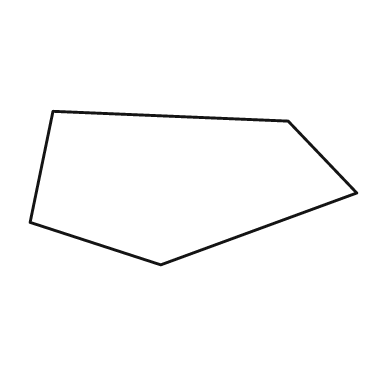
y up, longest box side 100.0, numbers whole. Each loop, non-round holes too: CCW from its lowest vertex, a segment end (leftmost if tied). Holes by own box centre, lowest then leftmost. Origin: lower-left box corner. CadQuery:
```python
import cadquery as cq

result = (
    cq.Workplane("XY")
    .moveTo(40.0, 0.0)
    .lineTo(100.0, 22.0)
    .lineTo(79.0, 44.0)
    .lineTo(7.0, 47.0)
    .lineTo(0.0, 13.0)
    .close()
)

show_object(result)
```